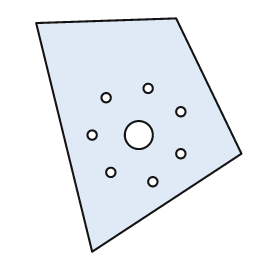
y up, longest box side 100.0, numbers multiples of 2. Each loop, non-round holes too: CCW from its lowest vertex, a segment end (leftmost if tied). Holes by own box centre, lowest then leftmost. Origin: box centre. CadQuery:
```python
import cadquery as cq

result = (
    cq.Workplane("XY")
    .moveTo(-20.0, -50.0)
    .lineTo(44.0, -8.0)
    .lineTo(16.0, 50.0)
    .lineTo(-44.0, 48.0)
    .close()
    .moveTo(6.0, -20.0)
    .circle(2.0)
    .moveTo(-12.0, -16.0)
    .circle(2.0)
    .moveTo(18.0, -8.0)
    .circle(2.0)
    .moveTo(-20.0, 0.0)
    .circle(2.0)
    .moveTo(0.0, 0.0)
    .circle(6.0)
    .moveTo(18.0, 10.0)
    .circle(2.0)
    .moveTo(-14.0, 16.0)
    .circle(2.0)
    .moveTo(4.0, 20.0)
    .circle(2.0)
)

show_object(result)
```